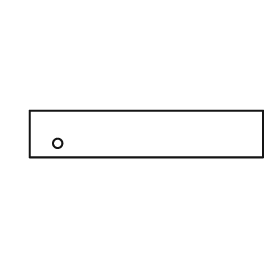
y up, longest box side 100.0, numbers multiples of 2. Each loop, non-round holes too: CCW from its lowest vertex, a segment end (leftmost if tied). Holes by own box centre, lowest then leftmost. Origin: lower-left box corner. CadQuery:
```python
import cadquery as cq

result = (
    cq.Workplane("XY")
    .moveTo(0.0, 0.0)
    .lineTo(100.0, 0.0)
    .lineTo(100.0, 20.0)
    .lineTo(0.0, 20.0)
    .close()
    .moveTo(12.0, 6.0)
    .circle(2.0)
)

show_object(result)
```